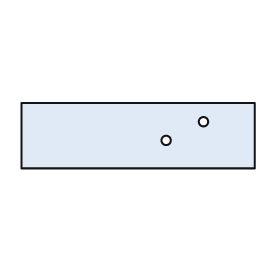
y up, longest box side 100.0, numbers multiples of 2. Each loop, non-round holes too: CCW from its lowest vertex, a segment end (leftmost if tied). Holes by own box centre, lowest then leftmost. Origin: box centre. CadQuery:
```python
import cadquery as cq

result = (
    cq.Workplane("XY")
    .moveTo(-50.0, -14.0)
    .lineTo(50.0, -14.0)
    .lineTo(50.0, 14.0)
    .lineTo(-50.0, 14.0)
    .close()
    .moveTo(12.0, -2.0)
    .circle(2.0)
    .moveTo(28.0, 6.0)
    .circle(2.0)
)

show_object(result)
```